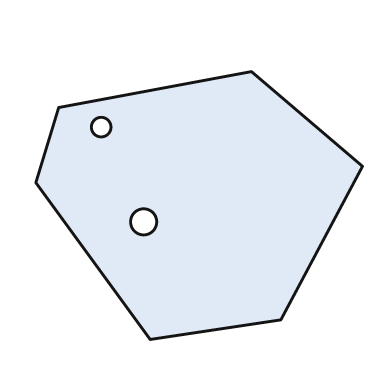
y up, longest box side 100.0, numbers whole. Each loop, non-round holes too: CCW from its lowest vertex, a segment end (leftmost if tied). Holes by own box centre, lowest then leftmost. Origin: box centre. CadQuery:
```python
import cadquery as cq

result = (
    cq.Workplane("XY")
    .moveTo(-15.0, -41.0)
    .lineTo(25.0, -35.0)
    .lineTo(50.0, 12.0)
    .lineTo(16.0, 41.0)
    .lineTo(-43.0, 30.0)
    .lineTo(-50.0, 7.0)
    .close()
    .moveTo(-17.0, -5.0)
    .circle(4.0)
    .moveTo(-30.0, 24.0)
    .circle(3.0)
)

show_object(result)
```